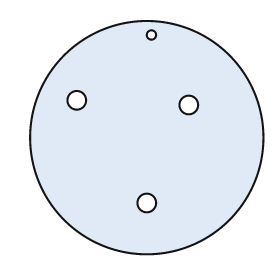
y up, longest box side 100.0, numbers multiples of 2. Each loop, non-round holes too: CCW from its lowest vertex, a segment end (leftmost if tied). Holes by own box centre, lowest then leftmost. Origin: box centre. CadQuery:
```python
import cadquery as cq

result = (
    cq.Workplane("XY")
    .moveTo(0.0, 0.0)
    .circle(50.0)
    .moveTo(0.0, -28.0)
    .circle(4.0)
    .moveTo(18.0, 14.0)
    .circle(4.0)
    .moveTo(-30.0, 16.0)
    .circle(4.0)
    .moveTo(2.0, 44.0)
    .circle(2.0)
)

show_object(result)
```